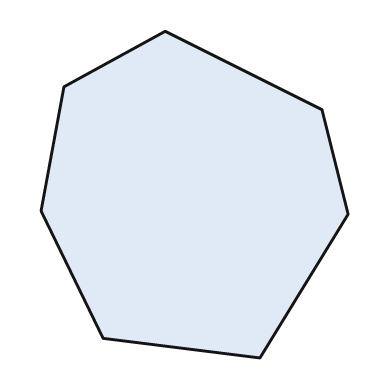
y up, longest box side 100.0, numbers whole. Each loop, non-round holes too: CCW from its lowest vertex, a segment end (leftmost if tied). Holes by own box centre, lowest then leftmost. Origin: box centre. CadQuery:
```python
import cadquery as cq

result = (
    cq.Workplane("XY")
    .moveTo(20.0, -50.0)
    .lineTo(47.0, -6.0)
    .lineTo(39.0, 26.0)
    .lineTo(-9.0, 50.0)
    .lineTo(-40.0, 33.0)
    .lineTo(-47.0, -5.0)
    .lineTo(-28.0, -44.0)
    .close()
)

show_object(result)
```